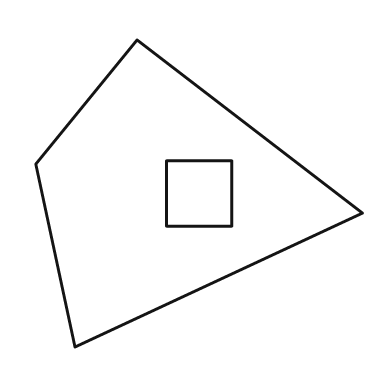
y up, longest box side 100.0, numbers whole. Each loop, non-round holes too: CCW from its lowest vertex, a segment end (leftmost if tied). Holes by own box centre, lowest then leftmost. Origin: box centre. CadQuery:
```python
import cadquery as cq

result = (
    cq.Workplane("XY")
    .moveTo(-38.0, -47.0)
    .lineTo(50.0, -6.0)
    .lineTo(-19.0, 47.0)
    .lineTo(-50.0, 9.0)
    .close()
    .moveTo(-10.0, -10.0)
    .lineTo(10.0, -10.0)
    .lineTo(10.0, 10.0)
    .lineTo(-10.0, 10.0)
    .close()
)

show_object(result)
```